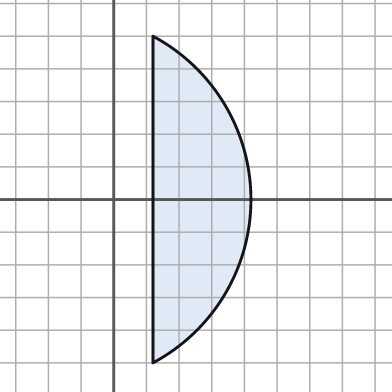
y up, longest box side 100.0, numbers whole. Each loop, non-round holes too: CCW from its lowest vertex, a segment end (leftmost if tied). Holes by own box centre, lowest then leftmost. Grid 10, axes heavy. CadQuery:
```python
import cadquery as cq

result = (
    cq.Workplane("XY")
    .moveTo(12.0, -50.0)
    .threePointArc((42.0, 0.0), (12.0, 50.0))
    .close()
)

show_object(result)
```